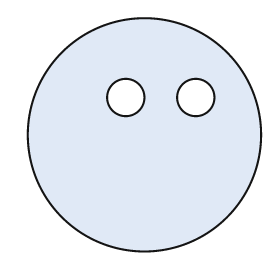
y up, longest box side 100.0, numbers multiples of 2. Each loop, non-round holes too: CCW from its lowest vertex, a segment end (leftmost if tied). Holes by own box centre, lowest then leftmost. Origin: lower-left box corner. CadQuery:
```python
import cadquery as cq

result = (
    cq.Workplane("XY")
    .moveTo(50.0, 50.0)
    .circle(50.0)
    .moveTo(42.0, 66.0)
    .circle(8.0)
    .moveTo(72.0, 66.0)
    .circle(8.0)
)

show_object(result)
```